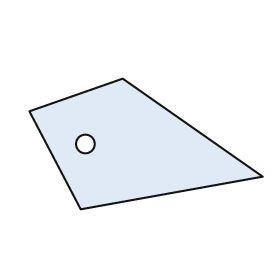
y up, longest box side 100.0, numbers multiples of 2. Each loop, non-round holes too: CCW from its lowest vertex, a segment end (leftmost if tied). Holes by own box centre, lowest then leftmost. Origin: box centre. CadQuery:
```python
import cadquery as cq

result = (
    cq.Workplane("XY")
    .moveTo(-28.0, -28.0)
    .lineTo(50.0, -14.0)
    .lineTo(-10.0, 28.0)
    .lineTo(-50.0, 14.0)
    .close()
    .moveTo(-26.0, 0.0)
    .circle(4.0)
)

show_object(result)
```